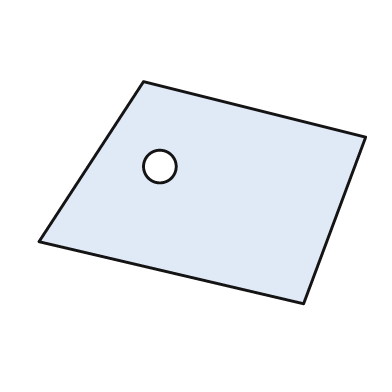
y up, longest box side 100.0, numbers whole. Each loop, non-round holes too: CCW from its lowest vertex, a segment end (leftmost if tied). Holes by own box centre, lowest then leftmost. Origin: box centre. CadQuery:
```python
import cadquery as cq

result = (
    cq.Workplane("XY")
    .moveTo(31.0, -34.0)
    .lineTo(50.0, 17.0)
    .lineTo(-18.0, 34.0)
    .lineTo(-50.0, -15.0)
    .close()
    .moveTo(-13.0, 8.0)
    .circle(5.0)
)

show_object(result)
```